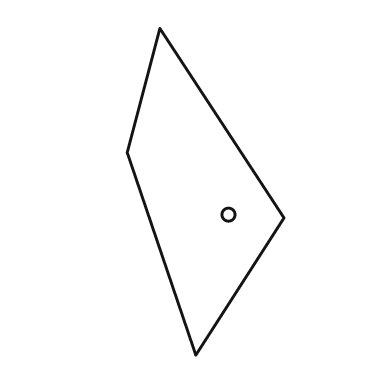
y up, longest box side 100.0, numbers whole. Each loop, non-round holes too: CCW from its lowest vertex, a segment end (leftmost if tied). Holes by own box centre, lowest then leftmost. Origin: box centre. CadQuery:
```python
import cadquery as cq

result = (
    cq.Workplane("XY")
    .moveTo(-3.0, -50.0)
    .lineTo(24.0, -8.0)
    .lineTo(-14.0, 50.0)
    .lineTo(-24.0, 12.0)
    .close()
    .moveTo(7.0, -7.0)
    .circle(2.0)
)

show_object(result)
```